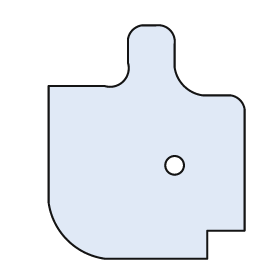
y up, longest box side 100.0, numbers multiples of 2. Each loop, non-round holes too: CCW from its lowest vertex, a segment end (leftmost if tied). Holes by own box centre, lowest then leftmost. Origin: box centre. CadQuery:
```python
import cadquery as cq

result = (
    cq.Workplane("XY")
    .moveTo(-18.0, -50.0)
    .lineTo(26.0, -50.0)
    .lineTo(26.0, -38.0)
    .lineTo(42.0, -38.0)
    .lineTo(42.0, 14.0)
    .threePointArc((40.0, 18.0), (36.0, 20.0))
    .lineTo(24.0, 20.0)
    .threePointArc((16.0, 24.0), (12.0, 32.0))
    .lineTo(12.0, 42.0)
    .threePointArc((10.0, 48.0), (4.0, 50.0))
    .lineTo(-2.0, 50.0)
    .threePointArc((-6.0, 48.0), (-8.0, 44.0))
    .lineTo(-8.0, 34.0)
    .threePointArc((-10.0, 26.0), (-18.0, 24.0))
    .lineTo(-42.0, 24.0)
    .lineTo(-42.0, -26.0)
    .threePointArc((-34.0, -42.0), (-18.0, -50.0))
    .close()
    .moveTo(12.0, -10.0)
    .circle(4.0)
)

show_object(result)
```